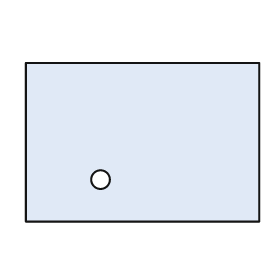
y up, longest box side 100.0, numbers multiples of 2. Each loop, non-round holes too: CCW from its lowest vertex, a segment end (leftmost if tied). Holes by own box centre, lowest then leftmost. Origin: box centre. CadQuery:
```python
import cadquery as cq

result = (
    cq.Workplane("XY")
    .moveTo(-50.0, -34.0)
    .lineTo(50.0, -34.0)
    .lineTo(50.0, 34.0)
    .lineTo(-50.0, 34.0)
    .close()
    .moveTo(-18.0, -16.0)
    .circle(4.0)
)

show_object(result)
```